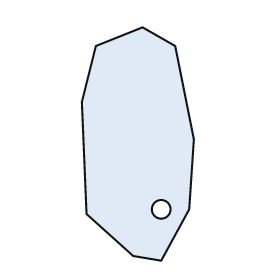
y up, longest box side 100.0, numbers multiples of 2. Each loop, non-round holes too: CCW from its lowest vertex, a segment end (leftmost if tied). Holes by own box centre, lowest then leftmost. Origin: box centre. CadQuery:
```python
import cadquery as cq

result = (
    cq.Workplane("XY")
    .moveTo(10.0, -50.0)
    .lineTo(22.0, -28.0)
    .lineTo(24.0, 2.0)
    .lineTo(16.0, 42.0)
    .lineTo(2.0, 50.0)
    .lineTo(-18.0, 42.0)
    .lineTo(-24.0, 18.0)
    .lineTo(-22.0, -30.0)
    .lineTo(-2.0, -48.0)
    .close()
    .moveTo(10.0, -28.0)
    .circle(4.0)
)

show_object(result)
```